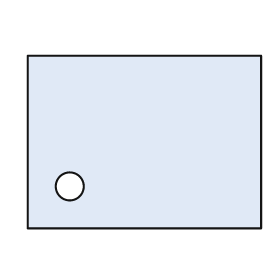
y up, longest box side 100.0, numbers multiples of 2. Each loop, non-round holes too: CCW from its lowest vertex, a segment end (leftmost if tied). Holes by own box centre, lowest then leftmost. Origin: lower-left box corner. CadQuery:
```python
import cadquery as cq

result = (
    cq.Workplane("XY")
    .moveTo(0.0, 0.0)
    .lineTo(100.0, 0.0)
    .lineTo(100.0, 74.0)
    .lineTo(0.0, 74.0)
    .close()
    .moveTo(18.0, 18.0)
    .circle(6.0)
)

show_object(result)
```